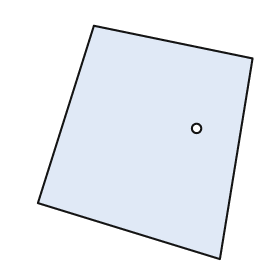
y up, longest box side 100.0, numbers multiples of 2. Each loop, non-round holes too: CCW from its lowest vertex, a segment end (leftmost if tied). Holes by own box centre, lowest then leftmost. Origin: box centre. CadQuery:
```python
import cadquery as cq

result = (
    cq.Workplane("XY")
    .moveTo(32.0, -50.0)
    .lineTo(46.0, 36.0)
    .lineTo(-22.0, 50.0)
    .lineTo(-46.0, -26.0)
    .close()
    .moveTo(22.0, 6.0)
    .circle(2.0)
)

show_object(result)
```